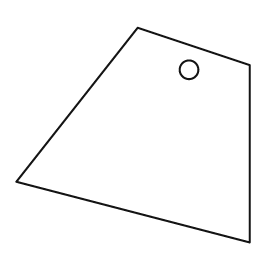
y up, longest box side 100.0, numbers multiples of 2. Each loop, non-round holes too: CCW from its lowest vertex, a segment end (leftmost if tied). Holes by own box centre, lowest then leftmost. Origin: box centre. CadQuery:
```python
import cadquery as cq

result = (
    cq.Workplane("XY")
    .moveTo(50.0, -46.0)
    .lineTo(50.0, 30.0)
    .lineTo(2.0, 46.0)
    .lineTo(-50.0, -20.0)
    .close()
    .moveTo(24.0, 28.0)
    .circle(4.0)
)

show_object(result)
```